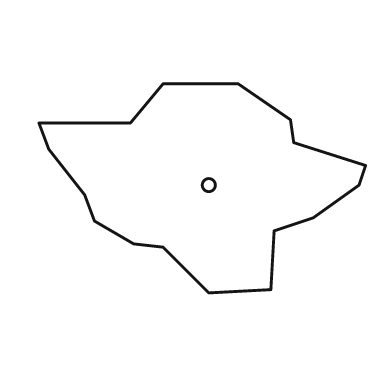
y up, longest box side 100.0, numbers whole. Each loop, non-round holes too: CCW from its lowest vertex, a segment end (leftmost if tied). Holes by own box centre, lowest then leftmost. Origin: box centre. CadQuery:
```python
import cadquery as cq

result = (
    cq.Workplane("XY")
    .moveTo(2.0, -32.0)
    .lineTo(21.0, -31.0)
    .lineTo(22.0, -13.0)
    .lineTo(34.0, -9.0)
    .lineTo(48.0, 1.0)
    .lineTo(50.0, 7.0)
    .lineTo(28.0, 14.0)
    .lineTo(27.0, 21.0)
    .lineTo(11.0, 32.0)
    .lineTo(-12.0, 32.0)
    .lineTo(-22.0, 20.0)
    .lineTo(-50.0, 20.0)
    .lineTo(-47.0, 12.0)
    .lineTo(-36.0, -2.0)
    .lineTo(-33.0, -10.0)
    .lineTo(-21.0, -17.0)
    .lineTo(-12.0, -18.0)
    .close()
    .moveTo(2.0, 1.0)
    .circle(2.0)
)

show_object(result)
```